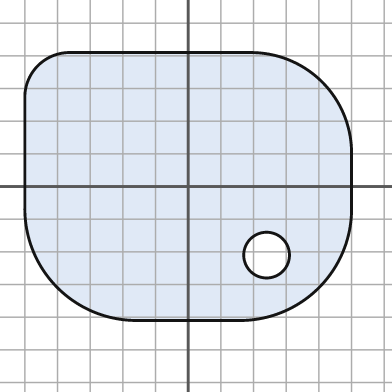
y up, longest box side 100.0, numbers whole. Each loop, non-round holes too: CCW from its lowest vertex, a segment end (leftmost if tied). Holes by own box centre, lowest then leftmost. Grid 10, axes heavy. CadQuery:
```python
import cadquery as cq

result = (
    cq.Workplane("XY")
    .moveTo(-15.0, -41.0)
    .lineTo(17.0, -41.0)
    .threePointArc((40.0, -31.0), (50.0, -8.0))
    .lineTo(50.0, 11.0)
    .threePointArc((41.0, 32.0), (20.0, 41.0))
    .lineTo(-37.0, 41.0)
    .threePointArc((-46.0, 37.0), (-50.0, 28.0))
    .lineTo(-50.0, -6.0)
    .threePointArc((-40.0, -31.0), (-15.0, -41.0))
    .close()
    .moveTo(24.0, -21.0)
    .circle(7.0)
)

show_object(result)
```